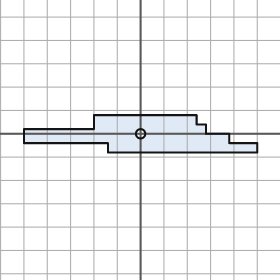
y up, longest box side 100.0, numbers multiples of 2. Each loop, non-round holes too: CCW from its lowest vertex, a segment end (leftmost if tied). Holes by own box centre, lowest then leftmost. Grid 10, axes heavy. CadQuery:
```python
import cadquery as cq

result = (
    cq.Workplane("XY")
    .moveTo(-14.0, -8.0)
    .lineTo(50.0, -8.0)
    .lineTo(50.0, -4.0)
    .lineTo(38.0, -4.0)
    .lineTo(38.0, 0.0)
    .lineTo(28.0, 0.0)
    .lineTo(28.0, 4.0)
    .lineTo(24.0, 4.0)
    .lineTo(24.0, 8.0)
    .lineTo(-20.0, 8.0)
    .lineTo(-20.0, 2.0)
    .lineTo(-50.0, 2.0)
    .lineTo(-50.0, -4.0)
    .lineTo(-14.0, -4.0)
    .close()
    .moveTo(0.0, 0.0)
    .circle(2.0)
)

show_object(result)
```